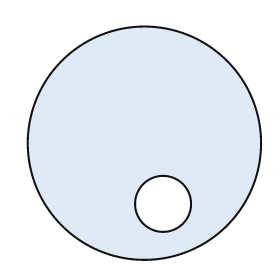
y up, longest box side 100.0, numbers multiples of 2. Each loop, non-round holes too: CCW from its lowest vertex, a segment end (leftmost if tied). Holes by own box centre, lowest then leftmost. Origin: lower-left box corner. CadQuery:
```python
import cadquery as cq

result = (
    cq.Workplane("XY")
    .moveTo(50.0, 50.0)
    .circle(50.0)
    .moveTo(58.0, 24.0)
    .circle(12.0)
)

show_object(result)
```